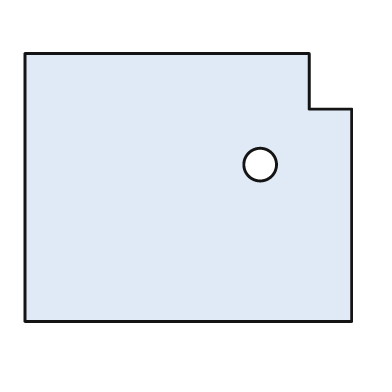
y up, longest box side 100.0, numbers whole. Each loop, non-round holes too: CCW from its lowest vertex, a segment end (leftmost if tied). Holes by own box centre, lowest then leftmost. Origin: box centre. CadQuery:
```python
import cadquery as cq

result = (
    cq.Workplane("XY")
    .moveTo(-50.0, -41.0)
    .lineTo(50.0, -41.0)
    .lineTo(50.0, 24.0)
    .lineTo(37.0, 24.0)
    .lineTo(37.0, 41.0)
    .lineTo(-50.0, 41.0)
    .close()
    .moveTo(22.0, 7.0)
    .circle(5.0)
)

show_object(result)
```